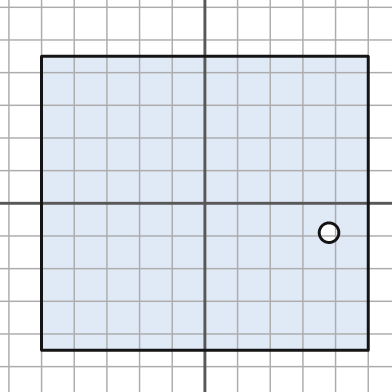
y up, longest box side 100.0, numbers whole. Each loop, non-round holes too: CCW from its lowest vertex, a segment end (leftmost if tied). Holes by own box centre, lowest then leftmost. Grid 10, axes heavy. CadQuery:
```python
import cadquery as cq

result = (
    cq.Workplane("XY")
    .moveTo(-50.0, -45.0)
    .lineTo(50.0, -45.0)
    .lineTo(50.0, 45.0)
    .lineTo(-50.0, 45.0)
    .close()
    .moveTo(38.0, -9.0)
    .circle(3.0)
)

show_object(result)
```